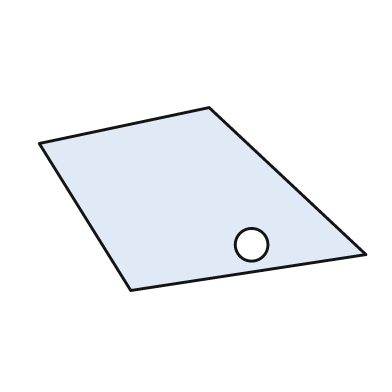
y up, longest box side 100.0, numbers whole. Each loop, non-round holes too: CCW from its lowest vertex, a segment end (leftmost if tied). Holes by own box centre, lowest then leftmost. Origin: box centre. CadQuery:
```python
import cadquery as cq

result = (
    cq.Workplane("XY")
    .moveTo(-22.0, -28.0)
    .lineTo(50.0, -17.0)
    .lineTo(2.0, 28.0)
    .lineTo(-50.0, 17.0)
    .close()
    .moveTo(15.0, -14.0)
    .circle(5.0)
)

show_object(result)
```